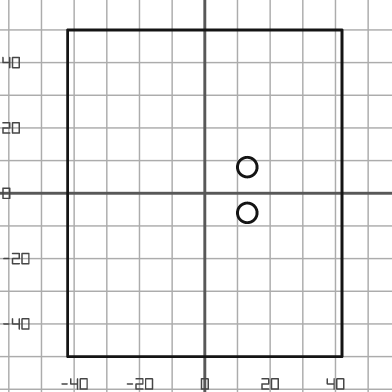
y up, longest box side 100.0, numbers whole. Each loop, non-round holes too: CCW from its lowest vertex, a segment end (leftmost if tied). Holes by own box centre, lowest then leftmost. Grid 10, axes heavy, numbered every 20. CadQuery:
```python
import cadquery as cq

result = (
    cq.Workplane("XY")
    .moveTo(-42.0, -50.0)
    .lineTo(42.0, -50.0)
    .lineTo(42.0, 50.0)
    .lineTo(-42.0, 50.0)
    .close()
    .moveTo(13.0, -6.0)
    .circle(3.0)
    .moveTo(13.0, 8.0)
    .circle(3.0)
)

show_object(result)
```